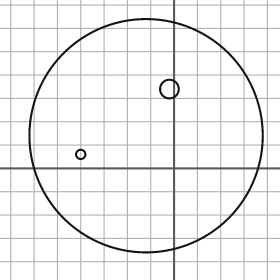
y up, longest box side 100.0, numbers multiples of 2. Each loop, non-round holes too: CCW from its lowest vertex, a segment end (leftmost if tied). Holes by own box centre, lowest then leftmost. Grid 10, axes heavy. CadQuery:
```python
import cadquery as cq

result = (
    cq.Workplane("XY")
    .moveTo(-12.0, 14.0)
    .circle(50.0)
    .moveTo(-40.0, 6.0)
    .circle(2.0)
    .moveTo(-2.0, 34.0)
    .circle(4.0)
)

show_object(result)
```